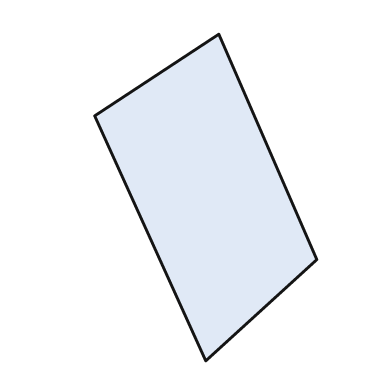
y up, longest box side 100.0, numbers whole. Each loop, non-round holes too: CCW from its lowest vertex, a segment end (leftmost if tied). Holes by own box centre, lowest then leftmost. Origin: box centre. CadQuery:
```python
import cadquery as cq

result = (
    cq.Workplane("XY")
    .moveTo(0.0, -50.0)
    .lineTo(34.0, -19.0)
    .lineTo(4.0, 50.0)
    .lineTo(-34.0, 25.0)
    .close()
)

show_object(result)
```